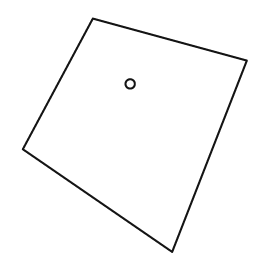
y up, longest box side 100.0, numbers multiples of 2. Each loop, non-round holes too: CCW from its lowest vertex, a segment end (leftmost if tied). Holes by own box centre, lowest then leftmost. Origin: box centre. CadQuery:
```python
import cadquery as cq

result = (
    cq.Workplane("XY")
    .moveTo(16.0, -50.0)
    .lineTo(48.0, 32.0)
    .lineTo(-18.0, 50.0)
    .lineTo(-48.0, -6.0)
    .close()
    .moveTo(-2.0, 22.0)
    .circle(2.0)
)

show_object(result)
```